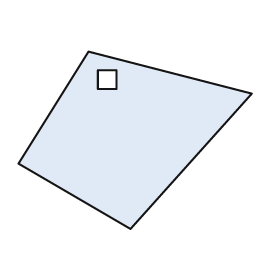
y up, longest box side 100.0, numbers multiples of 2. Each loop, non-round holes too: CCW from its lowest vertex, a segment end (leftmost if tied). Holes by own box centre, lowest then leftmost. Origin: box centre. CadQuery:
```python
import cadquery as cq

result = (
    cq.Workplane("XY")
    .moveTo(-2.0, -38.0)
    .lineTo(50.0, 20.0)
    .lineTo(-20.0, 38.0)
    .lineTo(-50.0, -10.0)
    .close()
    .moveTo(-16.0, 22.0)
    .lineTo(-8.0, 22.0)
    .lineTo(-8.0, 30.0)
    .lineTo(-16.0, 30.0)
    .close()
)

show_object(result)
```